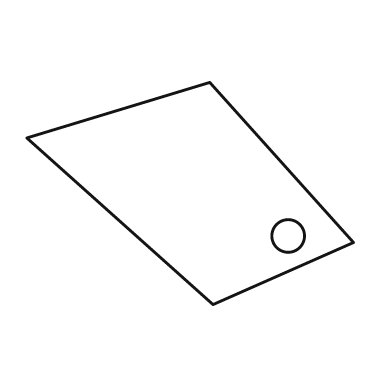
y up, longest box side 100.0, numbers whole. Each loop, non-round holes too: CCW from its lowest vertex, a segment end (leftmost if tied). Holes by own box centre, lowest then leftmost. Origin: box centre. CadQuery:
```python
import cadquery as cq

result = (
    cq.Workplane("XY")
    .moveTo(7.0, -34.0)
    .lineTo(50.0, -15.0)
    .lineTo(6.0, 34.0)
    .lineTo(-50.0, 17.0)
    .close()
    .moveTo(30.0, -13.0)
    .circle(5.0)
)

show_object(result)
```